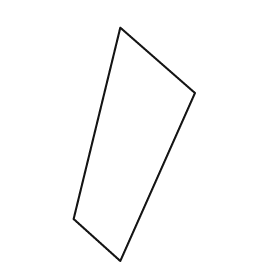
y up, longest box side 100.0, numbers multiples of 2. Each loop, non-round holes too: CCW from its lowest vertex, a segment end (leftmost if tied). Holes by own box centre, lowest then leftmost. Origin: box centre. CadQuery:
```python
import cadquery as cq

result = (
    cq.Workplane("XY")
    .moveTo(-6.0, -50.0)
    .lineTo(26.0, 22.0)
    .lineTo(-6.0, 50.0)
    .lineTo(-26.0, -32.0)
    .close()
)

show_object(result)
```